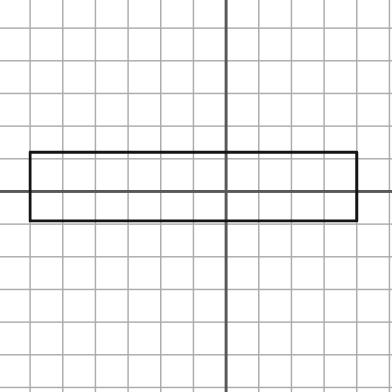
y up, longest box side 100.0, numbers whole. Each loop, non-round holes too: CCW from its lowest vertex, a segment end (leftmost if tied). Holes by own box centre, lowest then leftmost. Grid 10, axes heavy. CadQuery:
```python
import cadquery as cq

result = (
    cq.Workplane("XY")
    .moveTo(-60.0, -9.0)
    .lineTo(40.0, -9.0)
    .lineTo(40.0, 12.0)
    .lineTo(-60.0, 12.0)
    .close()
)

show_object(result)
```